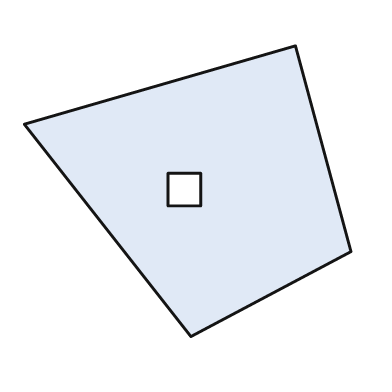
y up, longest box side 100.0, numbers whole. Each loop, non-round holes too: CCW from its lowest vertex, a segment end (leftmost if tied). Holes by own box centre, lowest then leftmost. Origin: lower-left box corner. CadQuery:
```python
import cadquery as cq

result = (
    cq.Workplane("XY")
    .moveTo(51.0, 0.0)
    .lineTo(100.0, 26.0)
    .lineTo(83.0, 89.0)
    .lineTo(0.0, 65.0)
    .close()
    .moveTo(44.0, 40.0)
    .lineTo(54.0, 40.0)
    .lineTo(54.0, 50.0)
    .lineTo(44.0, 50.0)
    .close()
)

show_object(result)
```